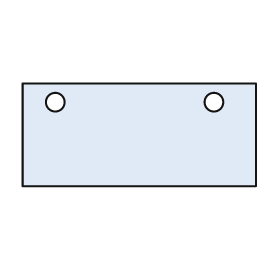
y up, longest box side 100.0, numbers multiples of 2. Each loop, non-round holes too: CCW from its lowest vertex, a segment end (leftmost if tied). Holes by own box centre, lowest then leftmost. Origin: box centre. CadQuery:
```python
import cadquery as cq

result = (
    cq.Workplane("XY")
    .moveTo(-50.0, -22.0)
    .lineTo(50.0, -22.0)
    .lineTo(50.0, 22.0)
    .lineTo(-50.0, 22.0)
    .close()
    .moveTo(-36.0, 14.0)
    .circle(4.0)
    .moveTo(32.0, 14.0)
    .circle(4.0)
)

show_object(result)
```